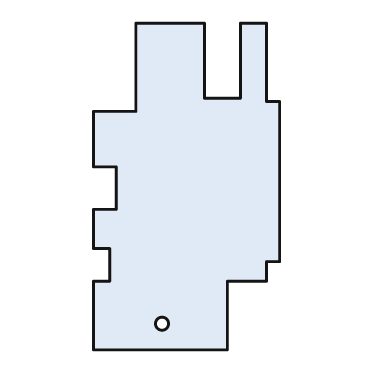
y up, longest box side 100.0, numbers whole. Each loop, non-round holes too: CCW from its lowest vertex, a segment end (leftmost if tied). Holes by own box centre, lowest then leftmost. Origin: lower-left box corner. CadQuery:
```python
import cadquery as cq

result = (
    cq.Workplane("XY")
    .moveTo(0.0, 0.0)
    .lineTo(41.0, 0.0)
    .lineTo(41.0, 21.0)
    .lineTo(53.0, 21.0)
    .lineTo(53.0, 27.0)
    .lineTo(57.0, 27.0)
    .lineTo(57.0, 76.0)
    .lineTo(53.0, 76.0)
    .lineTo(53.0, 100.0)
    .lineTo(45.0, 100.0)
    .lineTo(45.0, 77.0)
    .lineTo(34.0, 77.0)
    .lineTo(34.0, 100.0)
    .lineTo(13.0, 100.0)
    .lineTo(13.0, 73.0)
    .lineTo(0.0, 73.0)
    .lineTo(0.0, 56.0)
    .lineTo(7.0, 56.0)
    .lineTo(7.0, 43.0)
    .lineTo(0.0, 43.0)
    .lineTo(0.0, 31.0)
    .lineTo(5.0, 31.0)
    .lineTo(5.0, 21.0)
    .lineTo(0.0, 21.0)
    .close()
    .moveTo(21.0, 8.0)
    .circle(2.0)
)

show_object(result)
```